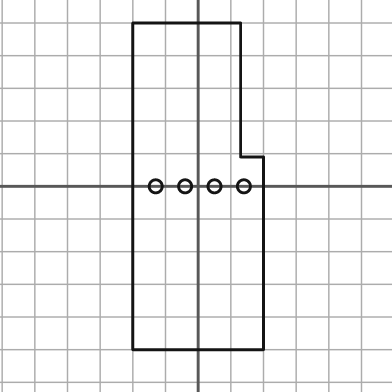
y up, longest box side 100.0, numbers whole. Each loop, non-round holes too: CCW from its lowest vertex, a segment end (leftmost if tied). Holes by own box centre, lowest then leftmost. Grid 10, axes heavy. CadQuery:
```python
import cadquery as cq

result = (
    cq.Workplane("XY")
    .moveTo(-20.0, -50.0)
    .lineTo(20.0, -50.0)
    .lineTo(20.0, 9.0)
    .lineTo(13.0, 9.0)
    .lineTo(13.0, 50.0)
    .lineTo(-20.0, 50.0)
    .close()
    .moveTo(-13.0, 0.0)
    .circle(2.0)
    .moveTo(-4.0, 0.0)
    .circle(2.0)
    .moveTo(5.0, 0.0)
    .circle(2.0)
    .moveTo(14.0, 0.0)
    .circle(2.0)
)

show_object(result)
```